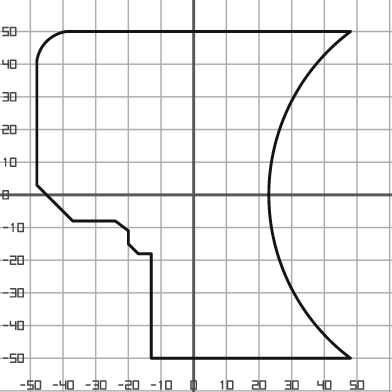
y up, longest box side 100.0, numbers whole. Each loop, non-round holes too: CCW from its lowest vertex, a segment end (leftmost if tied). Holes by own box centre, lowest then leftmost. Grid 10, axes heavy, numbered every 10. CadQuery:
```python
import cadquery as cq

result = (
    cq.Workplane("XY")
    .moveTo(-13.0, -50.0)
    .lineTo(48.0, -50.0)
    .threePointArc((23.0, 0.0), (48.0, 50.0))
    .lineTo(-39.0, 50.0)
    .threePointArc((-45.0, 47.0), (-48.0, 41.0))
    .lineTo(-48.0, 3.0)
    .lineTo(-37.0, -8.0)
    .lineTo(-24.0, -8.0)
    .lineTo(-20.0, -11.0)
    .lineTo(-20.0, -15.0)
    .lineTo(-17.0, -18.0)
    .lineTo(-13.0, -18.0)
    .close()
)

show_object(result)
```